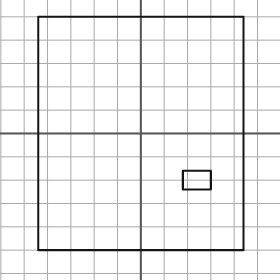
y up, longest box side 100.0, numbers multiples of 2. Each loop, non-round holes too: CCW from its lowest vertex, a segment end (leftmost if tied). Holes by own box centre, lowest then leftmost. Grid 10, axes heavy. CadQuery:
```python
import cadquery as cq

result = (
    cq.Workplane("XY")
    .moveTo(-44.0, -50.0)
    .lineTo(44.0, -50.0)
    .lineTo(44.0, 50.0)
    .lineTo(-44.0, 50.0)
    .close()
    .moveTo(18.0, -24.0)
    .lineTo(30.0, -24.0)
    .lineTo(30.0, -16.0)
    .lineTo(18.0, -16.0)
    .close()
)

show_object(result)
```